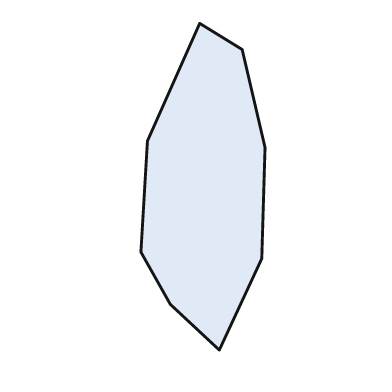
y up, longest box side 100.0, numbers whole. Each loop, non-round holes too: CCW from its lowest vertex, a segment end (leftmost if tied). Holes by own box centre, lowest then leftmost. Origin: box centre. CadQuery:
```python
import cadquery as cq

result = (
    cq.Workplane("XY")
    .moveTo(5.0, -50.0)
    .lineTo(18.0, -22.0)
    .lineTo(19.0, 12.0)
    .lineTo(12.0, 42.0)
    .lineTo(-1.0, 50.0)
    .lineTo(-17.0, 14.0)
    .lineTo(-19.0, -20.0)
    .lineTo(-10.0, -36.0)
    .close()
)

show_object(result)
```